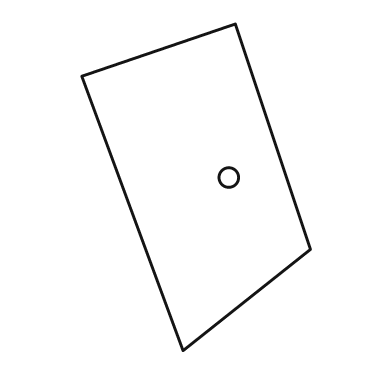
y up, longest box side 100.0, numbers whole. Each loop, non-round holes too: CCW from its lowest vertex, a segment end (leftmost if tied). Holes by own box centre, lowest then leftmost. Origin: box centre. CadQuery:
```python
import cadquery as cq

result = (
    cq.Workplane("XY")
    .moveTo(-4.0, -50.0)
    .lineTo(35.0, -19.0)
    .lineTo(12.0, 50.0)
    .lineTo(-35.0, 34.0)
    .close()
    .moveTo(10.0, 3.0)
    .circle(3.0)
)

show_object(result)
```